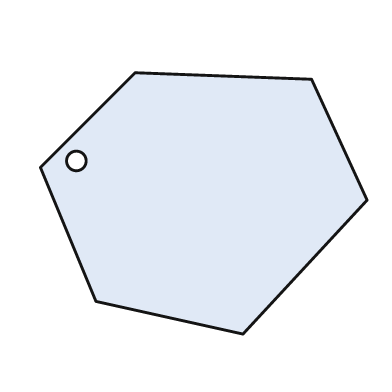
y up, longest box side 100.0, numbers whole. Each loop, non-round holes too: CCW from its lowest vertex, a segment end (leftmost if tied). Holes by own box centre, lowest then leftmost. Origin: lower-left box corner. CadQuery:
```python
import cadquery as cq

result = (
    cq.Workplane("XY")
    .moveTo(62.0, 0.0)
    .lineTo(100.0, 41.0)
    .lineTo(83.0, 78.0)
    .lineTo(29.0, 80.0)
    .lineTo(0.0, 51.0)
    .lineTo(17.0, 10.0)
    .close()
    .moveTo(11.0, 53.0)
    .circle(3.0)
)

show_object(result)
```